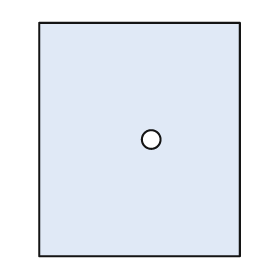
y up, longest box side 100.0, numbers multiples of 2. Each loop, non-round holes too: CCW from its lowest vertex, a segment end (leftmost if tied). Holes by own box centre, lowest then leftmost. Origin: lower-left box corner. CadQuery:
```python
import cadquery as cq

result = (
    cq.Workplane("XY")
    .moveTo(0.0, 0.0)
    .lineTo(86.0, 0.0)
    .lineTo(86.0, 100.0)
    .lineTo(0.0, 100.0)
    .close()
    .moveTo(48.0, 50.0)
    .circle(4.0)
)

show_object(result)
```